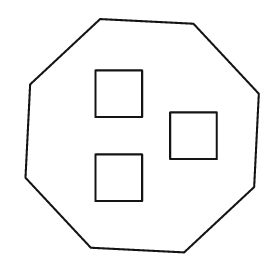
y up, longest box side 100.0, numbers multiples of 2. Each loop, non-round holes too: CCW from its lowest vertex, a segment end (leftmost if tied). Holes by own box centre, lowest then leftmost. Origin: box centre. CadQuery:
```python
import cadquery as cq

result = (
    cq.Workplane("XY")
    .moveTo(18.0, -50.0)
    .lineTo(48.0, -22.0)
    .lineTo(50.0, 18.0)
    .lineTo(22.0, 48.0)
    .lineTo(-18.0, 50.0)
    .lineTo(-48.0, 22.0)
    .lineTo(-50.0, -18.0)
    .lineTo(-22.0, -48.0)
    .close()
    .moveTo(-20.0, -28.0)
    .lineTo(0.0, -28.0)
    .lineTo(0.0, -8.0)
    .lineTo(-20.0, -8.0)
    .close()
    .moveTo(12.0, -10.0)
    .lineTo(32.0, -10.0)
    .lineTo(32.0, 10.0)
    .lineTo(12.0, 10.0)
    .close()
    .moveTo(-20.0, 8.0)
    .lineTo(0.0, 8.0)
    .lineTo(0.0, 28.0)
    .lineTo(-20.0, 28.0)
    .close()
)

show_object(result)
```